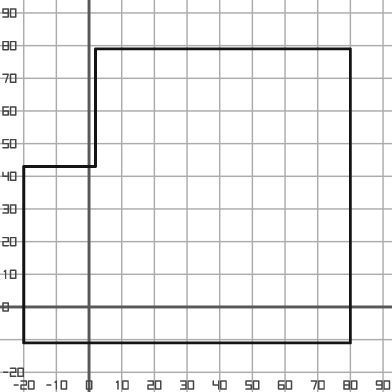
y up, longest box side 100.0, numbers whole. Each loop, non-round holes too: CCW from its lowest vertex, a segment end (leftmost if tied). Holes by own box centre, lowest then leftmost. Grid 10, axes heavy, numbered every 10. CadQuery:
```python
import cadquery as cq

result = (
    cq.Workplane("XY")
    .moveTo(-20.0, -11.0)
    .lineTo(80.0, -11.0)
    .lineTo(80.0, 79.0)
    .lineTo(2.0, 79.0)
    .lineTo(2.0, 43.0)
    .lineTo(-20.0, 43.0)
    .close()
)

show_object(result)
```